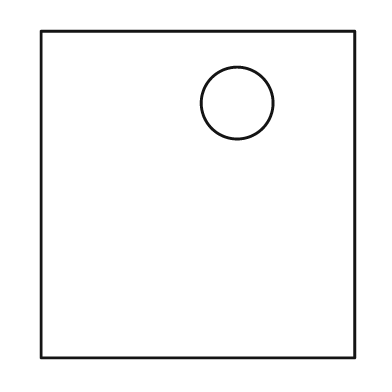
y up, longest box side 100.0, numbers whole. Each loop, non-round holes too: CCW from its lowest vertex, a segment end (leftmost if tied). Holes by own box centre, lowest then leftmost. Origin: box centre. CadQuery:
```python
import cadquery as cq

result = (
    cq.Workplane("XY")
    .moveTo(-48.0, -50.0)
    .lineTo(48.0, -50.0)
    .lineTo(48.0, 50.0)
    .lineTo(-48.0, 50.0)
    .close()
    .moveTo(12.0, 28.0)
    .circle(11.0)
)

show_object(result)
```